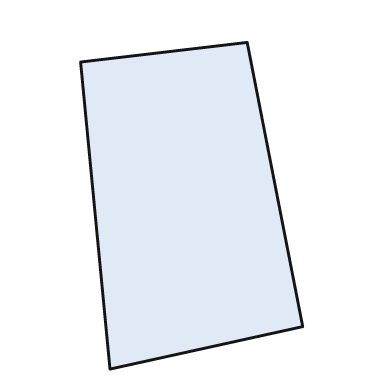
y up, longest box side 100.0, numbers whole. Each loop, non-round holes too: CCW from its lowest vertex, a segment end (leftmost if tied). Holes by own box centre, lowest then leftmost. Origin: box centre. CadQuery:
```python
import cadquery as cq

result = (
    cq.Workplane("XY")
    .moveTo(-25.0, -50.0)
    .lineTo(34.0, -37.0)
    .lineTo(17.0, 50.0)
    .lineTo(-34.0, 44.0)
    .close()
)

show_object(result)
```